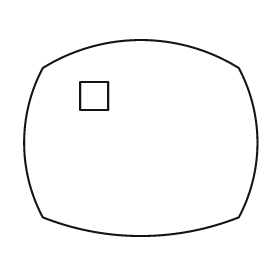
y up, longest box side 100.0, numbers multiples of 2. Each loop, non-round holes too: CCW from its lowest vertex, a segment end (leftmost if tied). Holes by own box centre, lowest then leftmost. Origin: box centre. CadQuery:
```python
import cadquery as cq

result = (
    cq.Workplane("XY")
    .moveTo(-42.0, -34.0)
    .threePointArc((0.0, -42.0), (42.0, -34.0))
    .threePointArc((50.0, -2.0), (42.0, 30.0))
    .threePointArc((0.0, 42.0), (-42.0, 30.0))
    .threePointArc((-50.0, -2.0), (-42.0, -34.0))
    .close()
    .moveTo(-26.0, 12.0)
    .lineTo(-14.0, 12.0)
    .lineTo(-14.0, 24.0)
    .lineTo(-26.0, 24.0)
    .close()
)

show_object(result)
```